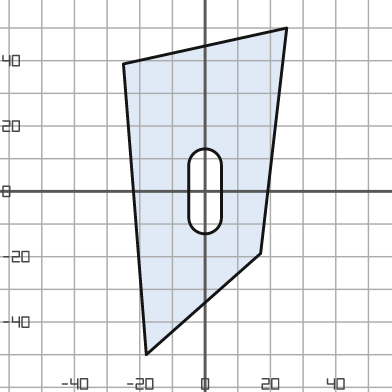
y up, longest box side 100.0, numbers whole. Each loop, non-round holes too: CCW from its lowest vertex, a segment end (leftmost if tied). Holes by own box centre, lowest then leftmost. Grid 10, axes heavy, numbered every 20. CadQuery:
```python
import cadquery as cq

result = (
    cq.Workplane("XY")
    .moveTo(-18.0, -50.0)
    .lineTo(17.0, -19.0)
    .lineTo(25.0, 50.0)
    .lineTo(-25.0, 39.0)
    .close()
    .moveTo(-5.0, -8.0)
    .threePointArc((0.0, -13.0), (5.0, -8.0))
    .lineTo(5.0, 8.0)
    .threePointArc((0.0, 13.0), (-5.0, 8.0))
    .close()
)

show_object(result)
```